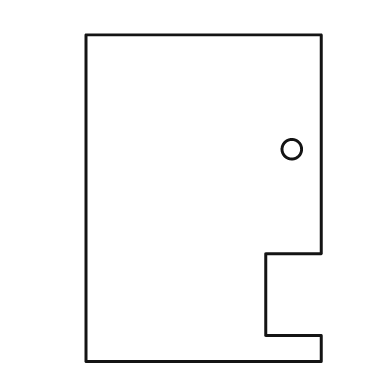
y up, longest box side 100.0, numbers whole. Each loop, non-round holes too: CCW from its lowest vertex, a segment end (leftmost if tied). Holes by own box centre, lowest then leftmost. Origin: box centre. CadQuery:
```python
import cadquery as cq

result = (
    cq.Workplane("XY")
    .moveTo(-36.0, -50.0)
    .lineTo(36.0, -50.0)
    .lineTo(36.0, -42.0)
    .lineTo(19.0, -42.0)
    .lineTo(19.0, -17.0)
    .lineTo(36.0, -17.0)
    .lineTo(36.0, 50.0)
    .lineTo(-36.0, 50.0)
    .close()
    .moveTo(27.0, 15.0)
    .circle(3.0)
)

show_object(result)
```